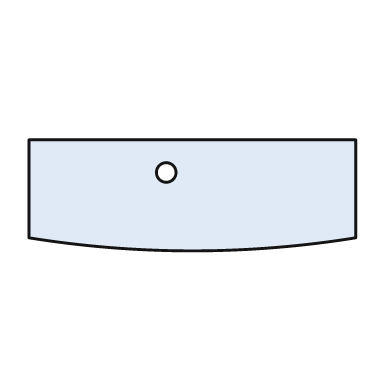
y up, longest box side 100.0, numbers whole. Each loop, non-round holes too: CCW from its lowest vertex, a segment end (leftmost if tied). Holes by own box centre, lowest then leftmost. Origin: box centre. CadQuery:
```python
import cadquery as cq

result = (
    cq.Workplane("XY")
    .moveTo(-50.0, -13.0)
    .threePointArc((0.0, -17.0), (50.0, -13.0))
    .lineTo(50.0, 17.0)
    .lineTo(-50.0, 17.0)
    .close()
    .moveTo(-8.0, 7.0)
    .circle(3.0)
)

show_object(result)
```